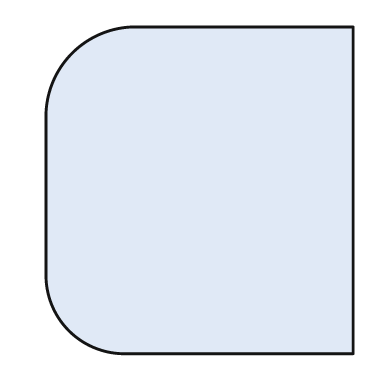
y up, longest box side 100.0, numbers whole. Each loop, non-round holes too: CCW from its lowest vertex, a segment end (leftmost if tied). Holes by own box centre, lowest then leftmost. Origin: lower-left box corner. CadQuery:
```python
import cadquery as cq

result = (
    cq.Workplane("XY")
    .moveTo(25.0, 0.0)
    .lineTo(94.0, 0.0)
    .lineTo(94.0, 100.0)
    .lineTo(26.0, 100.0)
    .threePointArc((8.0, 92.0), (0.0, 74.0))
    .lineTo(0.0, 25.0)
    .threePointArc((7.0, 7.0), (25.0, 0.0))
    .close()
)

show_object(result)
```